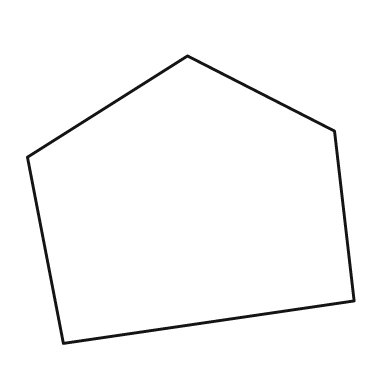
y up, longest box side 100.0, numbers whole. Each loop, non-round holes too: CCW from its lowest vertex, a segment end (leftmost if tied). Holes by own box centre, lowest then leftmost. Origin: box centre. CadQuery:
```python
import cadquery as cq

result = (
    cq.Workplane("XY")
    .moveTo(-39.0, -44.0)
    .lineTo(50.0, -31.0)
    .lineTo(44.0, 21.0)
    .lineTo(-1.0, 44.0)
    .lineTo(-50.0, 13.0)
    .close()
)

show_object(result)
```